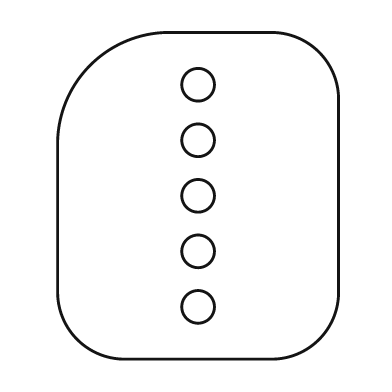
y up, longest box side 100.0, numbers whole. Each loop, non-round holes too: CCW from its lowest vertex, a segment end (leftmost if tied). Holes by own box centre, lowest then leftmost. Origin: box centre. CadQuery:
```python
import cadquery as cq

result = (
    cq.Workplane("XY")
    .moveTo(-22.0, -50.0)
    .lineTo(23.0, -50.0)
    .threePointArc((37.0, -44.0), (43.0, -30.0))
    .lineTo(43.0, 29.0)
    .threePointArc((37.0, 44.0), (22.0, 50.0))
    .lineTo(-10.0, 50.0)
    .threePointArc((-33.0, 40.0), (-43.0, 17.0))
    .lineTo(-43.0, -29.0)
    .threePointArc((-37.0, -44.0), (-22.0, -50.0))
    .close()
    .moveTo(0.0, -34.0)
    .circle(5.0)
    .moveTo(0.0, -17.0)
    .circle(5.0)
    .moveTo(0.0, 0.0)
    .circle(5.0)
    .moveTo(0.0, 17.0)
    .circle(5.0)
    .moveTo(0.0, 34.0)
    .circle(5.0)
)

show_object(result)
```